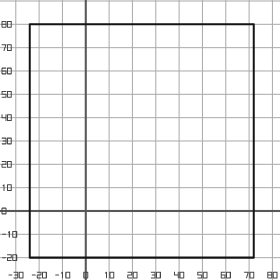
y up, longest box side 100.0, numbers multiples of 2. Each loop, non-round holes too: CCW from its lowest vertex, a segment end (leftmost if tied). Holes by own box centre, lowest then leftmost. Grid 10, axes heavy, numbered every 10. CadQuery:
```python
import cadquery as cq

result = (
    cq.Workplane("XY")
    .moveTo(-24.0, -20.0)
    .lineTo(72.0, -20.0)
    .lineTo(72.0, 80.0)
    .lineTo(-24.0, 80.0)
    .close()
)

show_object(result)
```